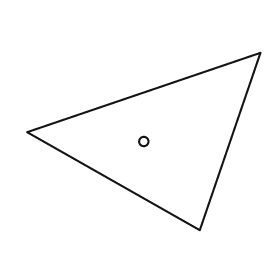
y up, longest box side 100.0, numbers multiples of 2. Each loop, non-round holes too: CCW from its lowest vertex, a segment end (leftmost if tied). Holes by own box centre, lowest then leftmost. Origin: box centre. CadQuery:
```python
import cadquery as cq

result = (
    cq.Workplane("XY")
    .moveTo(24.0, -38.0)
    .lineTo(50.0, 38.0)
    .lineTo(-50.0, 4.0)
    .close()
    .moveTo(0.0, 0.0)
    .circle(2.0)
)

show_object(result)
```